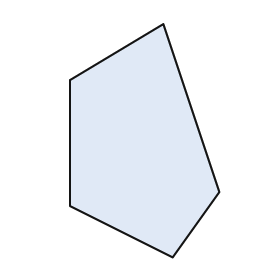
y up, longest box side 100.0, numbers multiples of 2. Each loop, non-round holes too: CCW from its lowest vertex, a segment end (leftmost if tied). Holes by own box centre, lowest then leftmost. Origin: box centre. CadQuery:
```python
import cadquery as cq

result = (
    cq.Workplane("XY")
    .moveTo(12.0, -50.0)
    .lineTo(32.0, -22.0)
    .lineTo(8.0, 50.0)
    .lineTo(-32.0, 26.0)
    .lineTo(-32.0, -28.0)
    .close()
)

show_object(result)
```